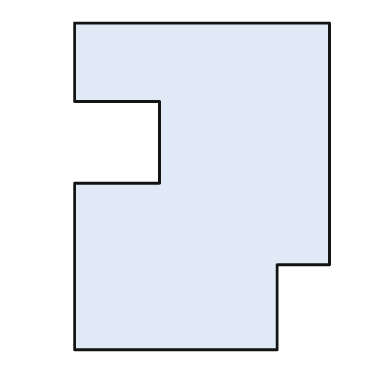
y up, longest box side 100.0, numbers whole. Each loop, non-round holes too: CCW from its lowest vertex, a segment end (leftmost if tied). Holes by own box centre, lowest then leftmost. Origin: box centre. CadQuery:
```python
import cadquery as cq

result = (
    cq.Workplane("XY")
    .moveTo(-39.0, -50.0)
    .lineTo(23.0, -50.0)
    .lineTo(23.0, -24.0)
    .lineTo(39.0, -24.0)
    .lineTo(39.0, 50.0)
    .lineTo(-39.0, 50.0)
    .lineTo(-39.0, 26.0)
    .lineTo(-13.0, 26.0)
    .lineTo(-13.0, 1.0)
    .lineTo(-39.0, 1.0)
    .close()
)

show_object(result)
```